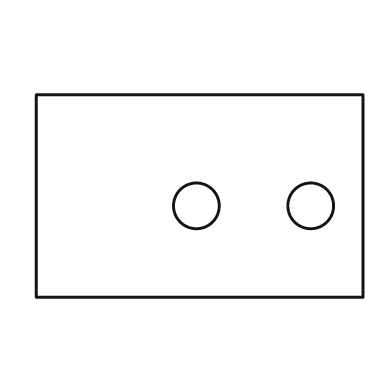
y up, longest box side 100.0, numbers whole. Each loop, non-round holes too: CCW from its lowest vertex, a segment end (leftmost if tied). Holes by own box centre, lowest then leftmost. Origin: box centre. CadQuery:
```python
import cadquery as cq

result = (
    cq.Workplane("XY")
    .moveTo(-50.0, -31.0)
    .lineTo(50.0, -31.0)
    .lineTo(50.0, 31.0)
    .lineTo(-50.0, 31.0)
    .close()
    .moveTo(-1.0, -3.0)
    .circle(7.0)
    .moveTo(34.0, -3.0)
    .circle(7.0)
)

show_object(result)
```